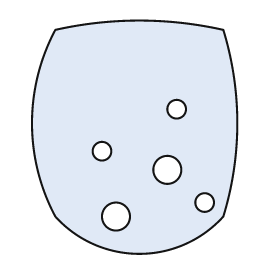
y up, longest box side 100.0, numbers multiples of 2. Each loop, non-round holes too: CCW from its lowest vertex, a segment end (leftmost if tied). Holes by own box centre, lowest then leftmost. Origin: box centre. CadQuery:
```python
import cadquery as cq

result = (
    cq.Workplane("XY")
    .moveTo(-34.0, -34.0)
    .threePointArc((2.0, -50.0), (38.0, -34.0))
    .threePointArc((44.0, 6.0), (38.0, 46.0))
    .threePointArc((2.0, 50.0), (-34.0, 46.0))
    .threePointArc((-44.0, 6.0), (-34.0, -34.0))
    .close()
    .moveTo(-8.0, -34.0)
    .circle(6.0)
    .moveTo(30.0, -28.0)
    .circle(4.0)
    .moveTo(14.0, -14.0)
    .circle(6.0)
    .moveTo(-14.0, -6.0)
    .circle(4.0)
    .moveTo(18.0, 12.0)
    .circle(4.0)
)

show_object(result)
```